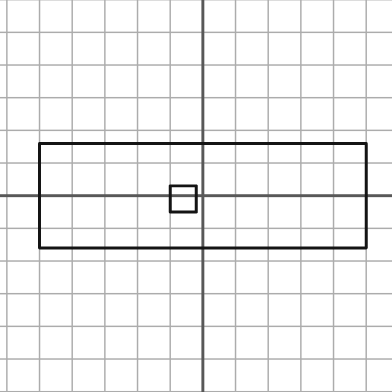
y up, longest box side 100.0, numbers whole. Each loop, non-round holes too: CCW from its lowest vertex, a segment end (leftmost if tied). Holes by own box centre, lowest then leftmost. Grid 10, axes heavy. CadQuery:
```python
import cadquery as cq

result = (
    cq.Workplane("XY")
    .moveTo(-50.0, -16.0)
    .lineTo(50.0, -16.0)
    .lineTo(50.0, 16.0)
    .lineTo(-50.0, 16.0)
    .close()
    .moveTo(-10.0, -5.0)
    .lineTo(-2.0, -5.0)
    .lineTo(-2.0, 3.0)
    .lineTo(-10.0, 3.0)
    .close()
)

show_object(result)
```